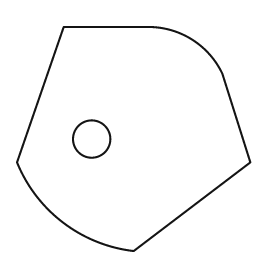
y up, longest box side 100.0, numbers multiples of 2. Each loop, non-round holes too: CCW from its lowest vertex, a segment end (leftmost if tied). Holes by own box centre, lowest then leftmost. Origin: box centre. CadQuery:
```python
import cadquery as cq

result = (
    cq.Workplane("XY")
    .moveTo(0.0, -48.0)
    .lineTo(50.0, -10.0)
    .lineTo(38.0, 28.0)
    .threePointArc((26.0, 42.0), (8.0, 48.0))
    .lineTo(-30.0, 48.0)
    .lineTo(-50.0, -10.0)
    .threePointArc((-30.0, -36.0), (0.0, -48.0))
    .close()
    .moveTo(-18.0, 0.0)
    .circle(8.0)
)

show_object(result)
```